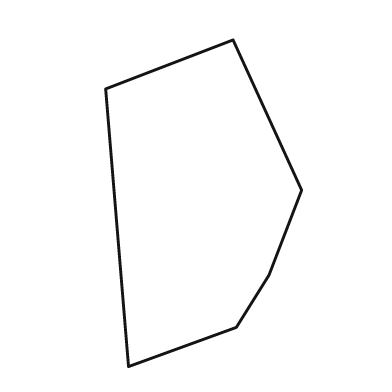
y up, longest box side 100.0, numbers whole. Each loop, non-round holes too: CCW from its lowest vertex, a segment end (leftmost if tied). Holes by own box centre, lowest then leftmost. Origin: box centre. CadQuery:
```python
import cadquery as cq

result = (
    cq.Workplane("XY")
    .moveTo(-23.0, -50.0)
    .lineTo(10.0, -38.0)
    .lineTo(20.0, -22.0)
    .lineTo(30.0, 4.0)
    .lineTo(9.0, 50.0)
    .lineTo(-30.0, 35.0)
    .close()
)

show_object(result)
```